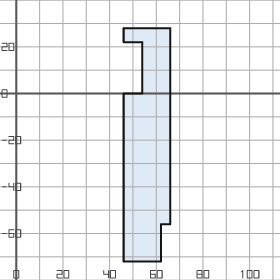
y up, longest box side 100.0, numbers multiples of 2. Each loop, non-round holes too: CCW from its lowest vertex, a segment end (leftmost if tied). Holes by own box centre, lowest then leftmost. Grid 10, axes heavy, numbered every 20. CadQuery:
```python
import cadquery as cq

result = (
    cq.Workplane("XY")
    .moveTo(46.0, -72.0)
    .lineTo(62.0, -72.0)
    .lineTo(62.0, -56.0)
    .lineTo(66.0, -56.0)
    .lineTo(66.0, 28.0)
    .lineTo(46.0, 28.0)
    .lineTo(46.0, 22.0)
    .lineTo(54.0, 22.0)
    .lineTo(54.0, 0.0)
    .lineTo(46.0, 0.0)
    .close()
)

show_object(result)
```